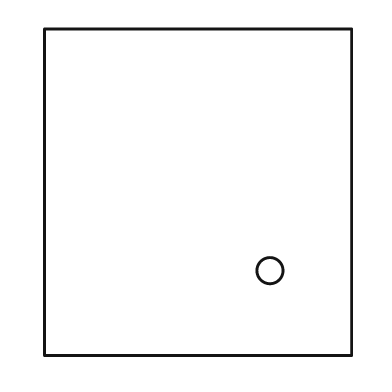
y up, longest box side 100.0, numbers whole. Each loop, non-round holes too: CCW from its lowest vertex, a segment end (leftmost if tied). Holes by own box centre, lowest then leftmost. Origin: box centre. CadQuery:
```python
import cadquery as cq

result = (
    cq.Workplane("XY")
    .moveTo(-47.0, -50.0)
    .lineTo(47.0, -50.0)
    .lineTo(47.0, 50.0)
    .lineTo(-47.0, 50.0)
    .close()
    .moveTo(22.0, -24.0)
    .circle(4.0)
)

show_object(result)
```